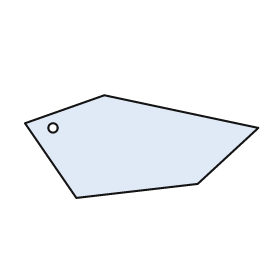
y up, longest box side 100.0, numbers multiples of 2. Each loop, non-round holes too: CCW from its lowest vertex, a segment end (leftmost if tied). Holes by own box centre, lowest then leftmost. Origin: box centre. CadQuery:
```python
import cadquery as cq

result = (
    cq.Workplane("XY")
    .moveTo(-28.0, -22.0)
    .lineTo(24.0, -16.0)
    .lineTo(50.0, 8.0)
    .lineTo(-16.0, 22.0)
    .lineTo(-50.0, 10.0)
    .close()
    .moveTo(-38.0, 8.0)
    .circle(2.0)
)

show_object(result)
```